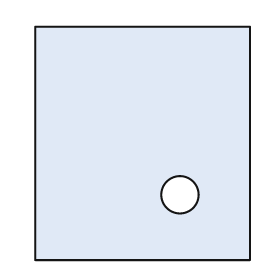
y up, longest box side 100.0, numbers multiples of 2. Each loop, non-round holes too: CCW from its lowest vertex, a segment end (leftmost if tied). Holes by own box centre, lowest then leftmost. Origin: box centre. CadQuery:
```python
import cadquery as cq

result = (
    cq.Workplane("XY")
    .moveTo(-46.0, -50.0)
    .lineTo(46.0, -50.0)
    .lineTo(46.0, 50.0)
    .lineTo(-46.0, 50.0)
    .close()
    .moveTo(16.0, -22.0)
    .circle(8.0)
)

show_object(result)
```